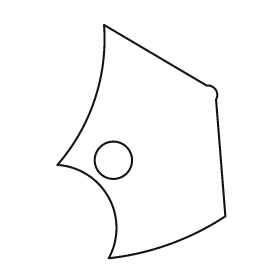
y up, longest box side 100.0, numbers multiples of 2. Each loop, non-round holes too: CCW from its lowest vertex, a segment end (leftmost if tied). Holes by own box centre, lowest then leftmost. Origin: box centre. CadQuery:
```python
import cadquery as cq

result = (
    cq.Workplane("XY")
    .moveTo(-14.0, -50.0)
    .threePointArc((12.0, -44.0), (36.0, -32.0))
    .lineTo(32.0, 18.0)
    .threePointArc((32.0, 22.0), (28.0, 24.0))
    .lineTo(-16.0, 50.0)
    .threePointArc((-20.0, 18.0), (-36.0, -10.0))
    .threePointArc((-14.0, -24.0), (-14.0, -50.0))
    .close()
    .moveTo(-12.0, -8.0)
    .circle(8.0)
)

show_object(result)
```